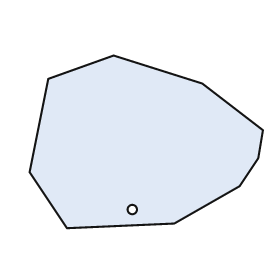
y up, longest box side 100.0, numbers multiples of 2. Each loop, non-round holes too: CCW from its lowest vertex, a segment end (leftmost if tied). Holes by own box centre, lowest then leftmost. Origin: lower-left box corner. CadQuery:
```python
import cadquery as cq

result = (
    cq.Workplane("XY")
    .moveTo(16.0, 0.0)
    .lineTo(62.0, 2.0)
    .lineTo(90.0, 18.0)
    .lineTo(98.0, 30.0)
    .lineTo(100.0, 42.0)
    .lineTo(74.0, 62.0)
    .lineTo(36.0, 74.0)
    .lineTo(8.0, 64.0)
    .lineTo(0.0, 24.0)
    .close()
    .moveTo(44.0, 8.0)
    .circle(2.0)
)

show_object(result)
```